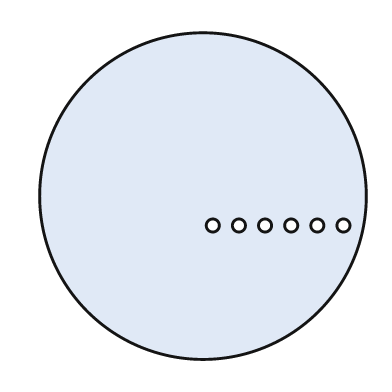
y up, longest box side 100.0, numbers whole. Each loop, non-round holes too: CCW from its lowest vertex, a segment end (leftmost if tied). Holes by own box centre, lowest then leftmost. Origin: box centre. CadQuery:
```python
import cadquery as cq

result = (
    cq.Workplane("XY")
    .moveTo(0.0, 0.0)
    .circle(50.0)
    .moveTo(3.0, -9.0)
    .circle(2.0)
    .moveTo(11.0, -9.0)
    .circle(2.0)
    .moveTo(19.0, -9.0)
    .circle(2.0)
    .moveTo(27.0, -9.0)
    .circle(2.0)
    .moveTo(35.0, -9.0)
    .circle(2.0)
    .moveTo(43.0, -9.0)
    .circle(2.0)
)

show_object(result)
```